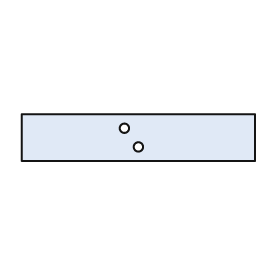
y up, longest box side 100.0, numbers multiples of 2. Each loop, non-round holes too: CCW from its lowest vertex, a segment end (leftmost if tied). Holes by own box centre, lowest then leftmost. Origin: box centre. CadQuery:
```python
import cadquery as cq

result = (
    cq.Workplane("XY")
    .moveTo(-50.0, -10.0)
    .lineTo(50.0, -10.0)
    .lineTo(50.0, 10.0)
    .lineTo(-50.0, 10.0)
    .close()
    .moveTo(0.0, -4.0)
    .circle(2.0)
    .moveTo(-6.0, 4.0)
    .circle(2.0)
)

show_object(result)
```